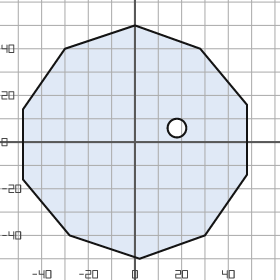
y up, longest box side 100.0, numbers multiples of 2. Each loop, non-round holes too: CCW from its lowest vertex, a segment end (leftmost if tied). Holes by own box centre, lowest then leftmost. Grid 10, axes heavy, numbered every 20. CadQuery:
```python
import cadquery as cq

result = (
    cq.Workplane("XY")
    .moveTo(2.0, -50.0)
    .lineTo(30.0, -40.0)
    .lineTo(48.0, -14.0)
    .lineTo(48.0, 16.0)
    .lineTo(28.0, 40.0)
    .lineTo(0.0, 50.0)
    .lineTo(-30.0, 40.0)
    .lineTo(-48.0, 14.0)
    .lineTo(-48.0, -16.0)
    .lineTo(-28.0, -40.0)
    .close()
    .moveTo(18.0, 6.0)
    .circle(4.0)
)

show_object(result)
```